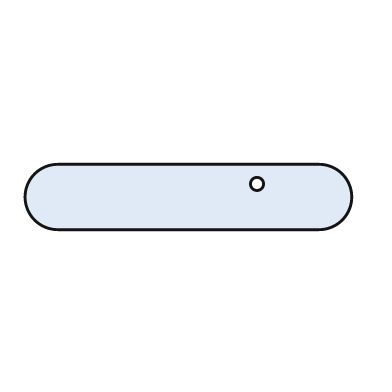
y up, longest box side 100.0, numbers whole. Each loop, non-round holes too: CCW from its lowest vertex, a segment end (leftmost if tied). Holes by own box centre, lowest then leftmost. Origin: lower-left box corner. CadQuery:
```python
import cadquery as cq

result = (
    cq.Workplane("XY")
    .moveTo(10.0, 0.0)
    .lineTo(90.0, 0.0)
    .threePointArc((100.0, 10.0), (90.0, 20.0))
    .lineTo(10.0, 20.0)
    .threePointArc((0.0, 10.0), (10.0, 0.0))
    .close()
    .moveTo(71.0, 14.0)
    .circle(2.0)
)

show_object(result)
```